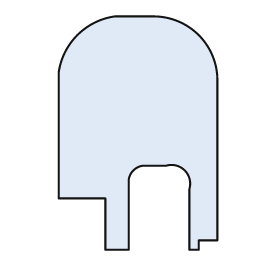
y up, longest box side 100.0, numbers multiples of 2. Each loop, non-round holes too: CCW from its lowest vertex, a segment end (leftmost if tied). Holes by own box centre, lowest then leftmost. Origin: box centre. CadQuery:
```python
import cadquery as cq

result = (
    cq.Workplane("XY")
    .moveTo(-14.0, -50.0)
    .lineTo(-4.0, -50.0)
    .lineTo(-4.0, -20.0)
    .threePointArc((-2.0, -16.0), (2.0, -14.0))
    .lineTo(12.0, -14.0)
    .threePointArc((20.0, -16.0), (22.0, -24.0))
    .lineTo(22.0, -50.0)
    .lineTo(26.0, -50.0)
    .lineTo(26.0, -46.0)
    .lineTo(34.0, -46.0)
    .lineTo(34.0, 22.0)
    .threePointArc((26.0, 42.0), (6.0, 50.0))
    .lineTo(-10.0, 50.0)
    .threePointArc((-26.0, 42.0), (-34.0, 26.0))
    .lineTo(-34.0, -28.0)
    .lineTo(-14.0, -28.0)
    .close()
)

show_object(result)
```